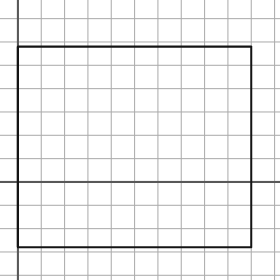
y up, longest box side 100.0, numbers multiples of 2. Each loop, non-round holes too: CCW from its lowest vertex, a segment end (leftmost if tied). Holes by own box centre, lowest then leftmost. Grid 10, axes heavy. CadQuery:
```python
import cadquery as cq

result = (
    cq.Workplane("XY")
    .moveTo(0.0, -28.0)
    .lineTo(100.0, -28.0)
    .lineTo(100.0, 58.0)
    .lineTo(0.0, 58.0)
    .close()
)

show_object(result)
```